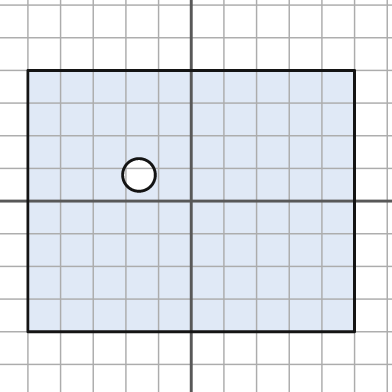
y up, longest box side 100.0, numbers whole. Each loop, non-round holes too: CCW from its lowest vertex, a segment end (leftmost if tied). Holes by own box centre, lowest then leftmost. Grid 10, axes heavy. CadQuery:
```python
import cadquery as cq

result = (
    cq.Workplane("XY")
    .moveTo(-50.0, -40.0)
    .lineTo(50.0, -40.0)
    .lineTo(50.0, 40.0)
    .lineTo(-50.0, 40.0)
    .close()
    .moveTo(-16.0, 8.0)
    .circle(5.0)
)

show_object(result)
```